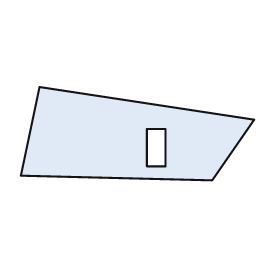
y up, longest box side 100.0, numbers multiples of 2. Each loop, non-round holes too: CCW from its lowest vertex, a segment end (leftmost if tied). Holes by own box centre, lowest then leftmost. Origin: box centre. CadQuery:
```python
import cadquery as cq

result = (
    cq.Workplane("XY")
    .moveTo(32.0, -20.0)
    .lineTo(50.0, 6.0)
    .lineTo(-42.0, 20.0)
    .lineTo(-50.0, -18.0)
    .close()
    .moveTo(4.0, -14.0)
    .lineTo(12.0, -14.0)
    .lineTo(12.0, 2.0)
    .lineTo(4.0, 2.0)
    .close()
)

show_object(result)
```